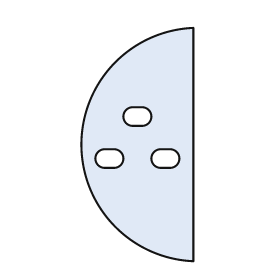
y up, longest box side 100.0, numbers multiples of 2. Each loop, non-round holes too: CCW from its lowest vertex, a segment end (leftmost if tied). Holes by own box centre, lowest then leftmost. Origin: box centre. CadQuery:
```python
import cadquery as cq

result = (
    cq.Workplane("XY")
    .moveTo(24.0, -50.0)
    .lineTo(24.0, 50.0)
    .threePointArc((-24.0, 0.0), (24.0, -50.0))
    .close()
    .moveTo(-14.0, -10.0)
    .lineTo(-10.0, -10.0)
    .threePointArc((-6.0, -6.0), (-10.0, -2.0))
    .lineTo(-14.0, -2.0)
    .threePointArc((-18.0, -6.0), (-14.0, -10.0))
    .close()
    .moveTo(10.0, -10.0)
    .lineTo(14.0, -10.0)
    .threePointArc((18.0, -6.0), (14.0, -2.0))
    .lineTo(10.0, -2.0)
    .threePointArc((6.0, -6.0), (10.0, -10.0))
    .close()
    .moveTo(-2.0, 8.0)
    .lineTo(2.0, 8.0)
    .threePointArc((6.0, 12.0), (2.0, 16.0))
    .lineTo(-2.0, 16.0)
    .threePointArc((-6.0, 12.0), (-2.0, 8.0))
    .close()
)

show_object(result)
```